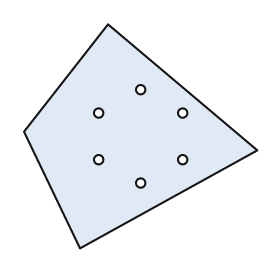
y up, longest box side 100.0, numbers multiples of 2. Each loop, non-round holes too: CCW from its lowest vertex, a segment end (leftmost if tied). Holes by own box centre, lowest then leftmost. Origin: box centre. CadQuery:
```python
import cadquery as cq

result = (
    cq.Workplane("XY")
    .moveTo(-26.0, -48.0)
    .lineTo(50.0, -6.0)
    .lineTo(-14.0, 48.0)
    .lineTo(-50.0, 2.0)
    .close()
    .moveTo(0.0, -20.0)
    .circle(2.0)
    .moveTo(-18.0, -10.0)
    .circle(2.0)
    .moveTo(18.0, -10.0)
    .circle(2.0)
    .moveTo(-18.0, 10.0)
    .circle(2.0)
    .moveTo(18.0, 10.0)
    .circle(2.0)
    .moveTo(0.0, 20.0)
    .circle(2.0)
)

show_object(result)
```